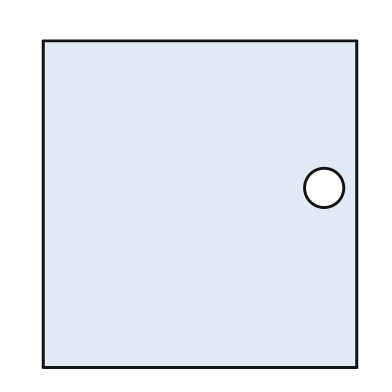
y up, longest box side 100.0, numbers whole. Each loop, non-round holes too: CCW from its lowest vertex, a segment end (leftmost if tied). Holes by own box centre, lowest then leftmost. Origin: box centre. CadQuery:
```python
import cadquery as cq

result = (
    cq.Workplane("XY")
    .moveTo(-48.0, -50.0)
    .lineTo(48.0, -50.0)
    .lineTo(48.0, 50.0)
    .lineTo(-48.0, 50.0)
    .close()
    .moveTo(38.0, 5.0)
    .circle(6.0)
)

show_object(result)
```